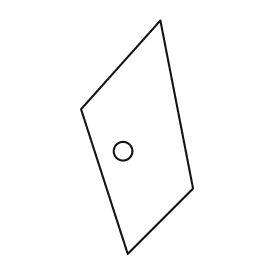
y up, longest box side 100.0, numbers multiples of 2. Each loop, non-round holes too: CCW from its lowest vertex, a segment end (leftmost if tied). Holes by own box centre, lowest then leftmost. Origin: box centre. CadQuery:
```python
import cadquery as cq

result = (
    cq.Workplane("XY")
    .moveTo(-4.0, -50.0)
    .lineTo(24.0, -22.0)
    .lineTo(10.0, 50.0)
    .lineTo(-24.0, 12.0)
    .close()
    .moveTo(-6.0, -6.0)
    .circle(4.0)
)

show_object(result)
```